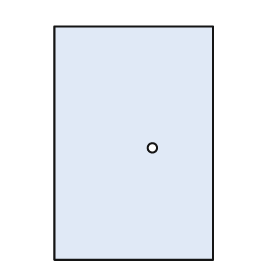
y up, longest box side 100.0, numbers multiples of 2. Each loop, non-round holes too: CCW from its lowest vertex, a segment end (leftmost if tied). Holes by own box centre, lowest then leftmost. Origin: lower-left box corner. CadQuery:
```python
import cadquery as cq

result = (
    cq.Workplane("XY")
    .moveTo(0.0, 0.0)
    .lineTo(68.0, 0.0)
    .lineTo(68.0, 100.0)
    .lineTo(0.0, 100.0)
    .close()
    .moveTo(42.0, 48.0)
    .circle(2.0)
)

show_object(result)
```